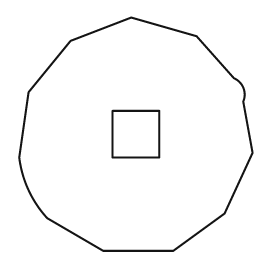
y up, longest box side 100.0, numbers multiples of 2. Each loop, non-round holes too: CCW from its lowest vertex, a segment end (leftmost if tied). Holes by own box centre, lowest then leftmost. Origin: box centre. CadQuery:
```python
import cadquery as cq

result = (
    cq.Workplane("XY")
    .moveTo(-14.0, -50.0)
    .lineTo(16.0, -50.0)
    .lineTo(38.0, -34.0)
    .lineTo(50.0, -8.0)
    .lineTo(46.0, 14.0)
    .threePointArc((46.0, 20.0), (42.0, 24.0))
    .lineTo(26.0, 42.0)
    .lineTo(-2.0, 50.0)
    .lineTo(-28.0, 40.0)
    .lineTo(-46.0, 18.0)
    .lineTo(-50.0, -10.0)
    .threePointArc((-46.0, -24.0), (-38.0, -36.0))
    .close()
    .moveTo(-10.0, -10.0)
    .lineTo(10.0, -10.0)
    .lineTo(10.0, 10.0)
    .lineTo(-10.0, 10.0)
    .close()
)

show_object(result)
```